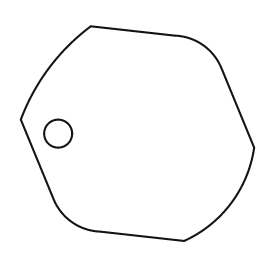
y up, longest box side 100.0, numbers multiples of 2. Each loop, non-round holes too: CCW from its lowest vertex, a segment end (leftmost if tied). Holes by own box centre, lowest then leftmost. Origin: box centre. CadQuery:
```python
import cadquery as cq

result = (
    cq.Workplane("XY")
    .moveTo(20.0, -46.0)
    .threePointArc((40.0, -30.0), (50.0, -6.0))
    .lineTo(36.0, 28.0)
    .threePointArc((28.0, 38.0), (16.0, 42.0))
    .lineTo(-20.0, 46.0)
    .threePointArc((-38.0, 28.0), (-50.0, 6.0))
    .lineTo(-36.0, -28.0)
    .threePointArc((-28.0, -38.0), (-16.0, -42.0))
    .close()
    .moveTo(-34.0, 0.0)
    .circle(6.0)
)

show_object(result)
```